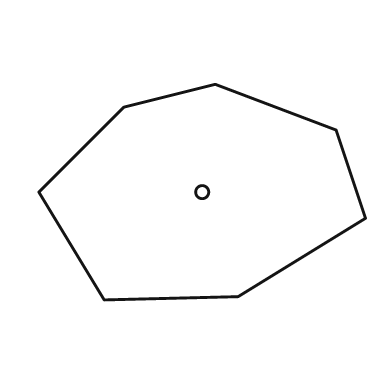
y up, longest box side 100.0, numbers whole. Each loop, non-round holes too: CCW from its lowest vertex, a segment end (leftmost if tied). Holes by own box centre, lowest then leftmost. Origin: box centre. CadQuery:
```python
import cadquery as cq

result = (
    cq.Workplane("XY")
    .moveTo(-30.0, -33.0)
    .lineTo(11.0, -32.0)
    .lineTo(50.0, -8.0)
    .lineTo(41.0, 19.0)
    .lineTo(4.0, 33.0)
    .lineTo(-24.0, 26.0)
    .lineTo(-50.0, 0.0)
    .close()
    .moveTo(0.0, 0.0)
    .circle(2.0)
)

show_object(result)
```